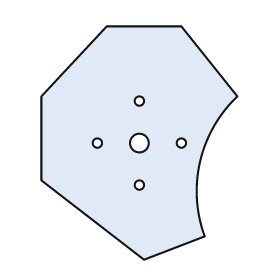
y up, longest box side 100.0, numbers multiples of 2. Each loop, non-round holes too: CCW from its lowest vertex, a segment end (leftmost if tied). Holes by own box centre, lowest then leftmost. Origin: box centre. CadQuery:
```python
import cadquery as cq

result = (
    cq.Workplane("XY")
    .moveTo(2.0, -50.0)
    .lineTo(28.0, -40.0)
    .threePointArc((26.0, -8.0), (42.0, 20.0))
    .lineTo(18.0, 50.0)
    .lineTo(-14.0, 50.0)
    .lineTo(-42.0, 20.0)
    .lineTo(-42.0, -16.0)
    .close()
    .moveTo(0.0, -18.0)
    .circle(2.0)
    .moveTo(-18.0, 0.0)
    .circle(2.0)
    .moveTo(0.0, 0.0)
    .circle(4.0)
    .moveTo(18.0, 0.0)
    .circle(2.0)
    .moveTo(0.0, 18.0)
    .circle(2.0)
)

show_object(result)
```